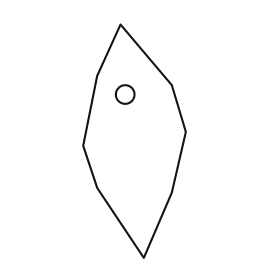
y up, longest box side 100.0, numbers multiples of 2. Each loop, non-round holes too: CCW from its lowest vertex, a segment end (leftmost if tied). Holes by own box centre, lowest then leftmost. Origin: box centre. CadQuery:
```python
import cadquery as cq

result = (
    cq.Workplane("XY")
    .moveTo(4.0, -50.0)
    .lineTo(16.0, -22.0)
    .lineTo(22.0, 4.0)
    .lineTo(16.0, 24.0)
    .lineTo(-6.0, 50.0)
    .lineTo(-16.0, 28.0)
    .lineTo(-22.0, -2.0)
    .lineTo(-16.0, -20.0)
    .close()
    .moveTo(-4.0, 20.0)
    .circle(4.0)
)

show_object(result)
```